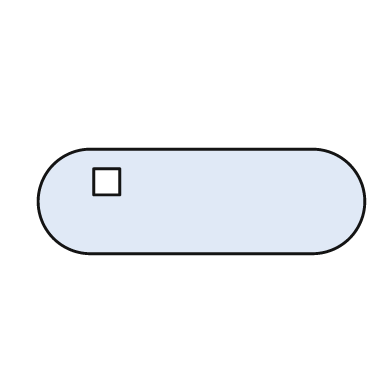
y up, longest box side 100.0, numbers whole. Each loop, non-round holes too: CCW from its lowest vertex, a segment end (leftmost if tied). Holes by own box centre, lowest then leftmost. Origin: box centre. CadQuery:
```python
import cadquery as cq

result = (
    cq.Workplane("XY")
    .moveTo(-34.0, -16.0)
    .lineTo(34.0, -16.0)
    .threePointArc((50.0, 0.0), (34.0, 16.0))
    .lineTo(-34.0, 16.0)
    .threePointArc((-50.0, 0.0), (-34.0, -16.0))
    .close()
    .moveTo(-33.0, 2.0)
    .lineTo(-25.0, 2.0)
    .lineTo(-25.0, 10.0)
    .lineTo(-33.0, 10.0)
    .close()
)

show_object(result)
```